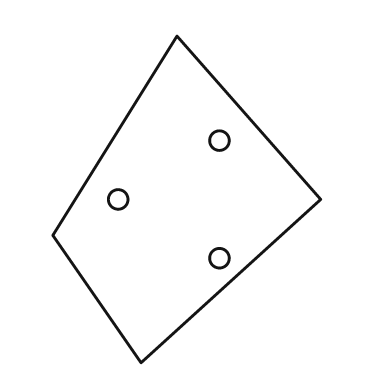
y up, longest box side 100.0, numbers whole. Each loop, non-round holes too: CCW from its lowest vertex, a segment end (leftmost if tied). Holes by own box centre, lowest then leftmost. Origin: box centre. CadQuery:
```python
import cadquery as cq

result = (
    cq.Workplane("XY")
    .moveTo(-14.0, -50.0)
    .lineTo(41.0, 0.0)
    .lineTo(-3.0, 50.0)
    .lineTo(-41.0, -11.0)
    .close()
    .moveTo(10.0, -18.0)
    .circle(3.0)
    .moveTo(-21.0, 0.0)
    .circle(3.0)
    .moveTo(10.0, 18.0)
    .circle(3.0)
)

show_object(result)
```